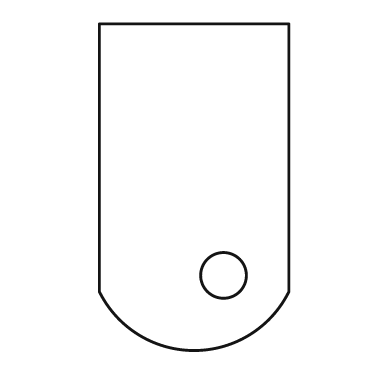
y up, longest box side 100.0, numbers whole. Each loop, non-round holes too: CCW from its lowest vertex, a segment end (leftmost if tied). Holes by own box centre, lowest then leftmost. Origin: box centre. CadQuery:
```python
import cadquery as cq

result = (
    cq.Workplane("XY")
    .moveTo(-29.0, -32.0)
    .threePointArc((0.0, -50.0), (29.0, -32.0))
    .lineTo(29.0, 50.0)
    .lineTo(-29.0, 50.0)
    .close()
    .moveTo(9.0, -27.0)
    .circle(7.0)
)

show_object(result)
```